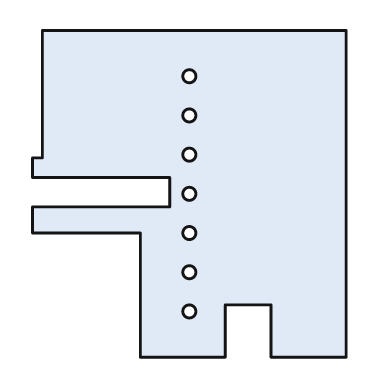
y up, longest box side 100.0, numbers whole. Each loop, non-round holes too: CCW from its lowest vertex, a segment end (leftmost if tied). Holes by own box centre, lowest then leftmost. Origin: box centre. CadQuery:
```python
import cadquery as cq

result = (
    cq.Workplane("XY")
    .moveTo(-15.0, -50.0)
    .lineTo(11.0, -50.0)
    .lineTo(11.0, -34.0)
    .lineTo(25.0, -34.0)
    .lineTo(25.0, -50.0)
    .lineTo(48.0, -50.0)
    .lineTo(48.0, 50.0)
    .lineTo(-45.0, 50.0)
    .lineTo(-45.0, 11.0)
    .lineTo(-48.0, 11.0)
    .lineTo(-48.0, 5.0)
    .lineTo(-6.0, 5.0)
    .lineTo(-6.0, -4.0)
    .lineTo(-48.0, -4.0)
    .lineTo(-48.0, -12.0)
    .lineTo(-15.0, -12.0)
    .close()
    .moveTo(0.0, -36.0)
    .circle(2.0)
    .moveTo(0.0, -24.0)
    .circle(2.0)
    .moveTo(0.0, -12.0)
    .circle(2.0)
    .moveTo(0.0, 0.0)
    .circle(2.0)
    .moveTo(0.0, 12.0)
    .circle(2.0)
    .moveTo(0.0, 24.0)
    .circle(2.0)
    .moveTo(0.0, 36.0)
    .circle(2.0)
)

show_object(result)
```